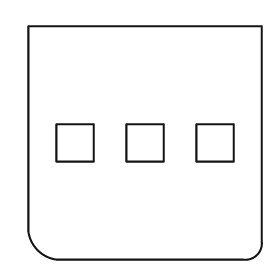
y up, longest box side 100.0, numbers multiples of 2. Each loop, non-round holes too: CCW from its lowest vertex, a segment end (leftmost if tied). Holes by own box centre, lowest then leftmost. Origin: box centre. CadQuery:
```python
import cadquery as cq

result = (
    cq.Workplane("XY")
    .moveTo(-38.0, -50.0)
    .lineTo(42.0, -50.0)
    .threePointArc((48.0, -48.0), (50.0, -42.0))
    .lineTo(50.0, 50.0)
    .lineTo(-50.0, 50.0)
    .lineTo(-50.0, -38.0)
    .threePointArc((-46.0, -46.0), (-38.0, -50.0))
    .close()
    .moveTo(-38.0, -8.0)
    .lineTo(-22.0, -8.0)
    .lineTo(-22.0, 8.0)
    .lineTo(-38.0, 8.0)
    .close()
    .moveTo(-8.0, -8.0)
    .lineTo(8.0, -8.0)
    .lineTo(8.0, 8.0)
    .lineTo(-8.0, 8.0)
    .close()
    .moveTo(22.0, -8.0)
    .lineTo(38.0, -8.0)
    .lineTo(38.0, 8.0)
    .lineTo(22.0, 8.0)
    .close()
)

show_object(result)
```